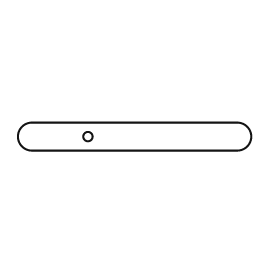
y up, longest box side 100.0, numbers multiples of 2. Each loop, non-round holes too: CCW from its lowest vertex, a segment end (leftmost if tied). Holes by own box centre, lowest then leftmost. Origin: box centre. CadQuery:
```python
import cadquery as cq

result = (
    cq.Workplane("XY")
    .moveTo(-44.0, -6.0)
    .lineTo(44.0, -6.0)
    .threePointArc((50.0, 0.0), (44.0, 6.0))
    .lineTo(-44.0, 6.0)
    .threePointArc((-50.0, 0.0), (-44.0, -6.0))
    .close()
    .moveTo(-20.0, 0.0)
    .circle(2.0)
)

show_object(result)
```